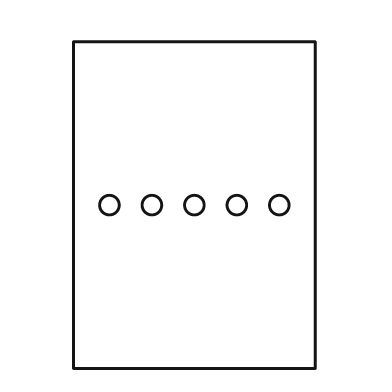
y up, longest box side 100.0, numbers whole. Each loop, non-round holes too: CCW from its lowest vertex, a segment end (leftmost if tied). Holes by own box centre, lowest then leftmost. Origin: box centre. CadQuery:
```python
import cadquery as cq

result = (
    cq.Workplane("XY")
    .moveTo(-37.0, -50.0)
    .lineTo(37.0, -50.0)
    .lineTo(37.0, 50.0)
    .lineTo(-37.0, 50.0)
    .close()
    .moveTo(-26.0, 0.0)
    .circle(3.0)
    .moveTo(-13.0, 0.0)
    .circle(3.0)
    .moveTo(0.0, 0.0)
    .circle(3.0)
    .moveTo(13.0, 0.0)
    .circle(3.0)
    .moveTo(26.0, 0.0)
    .circle(3.0)
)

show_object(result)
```